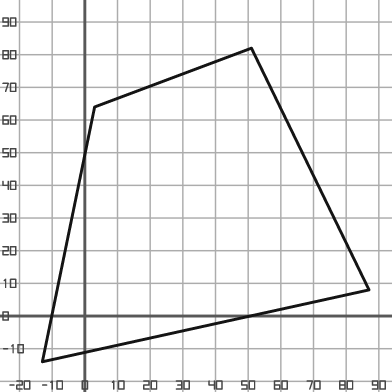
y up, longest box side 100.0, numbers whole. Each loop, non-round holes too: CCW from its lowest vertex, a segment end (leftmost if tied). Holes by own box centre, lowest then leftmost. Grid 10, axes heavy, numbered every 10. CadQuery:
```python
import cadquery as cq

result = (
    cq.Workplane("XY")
    .moveTo(-13.0, -14.0)
    .lineTo(87.0, 8.0)
    .lineTo(51.0, 82.0)
    .lineTo(3.0, 64.0)
    .close()
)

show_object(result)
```